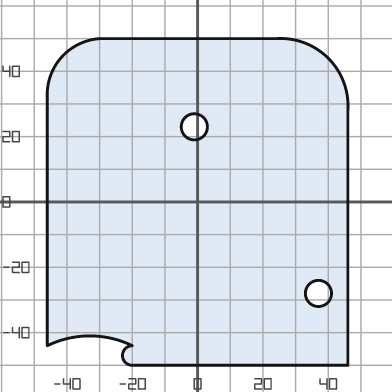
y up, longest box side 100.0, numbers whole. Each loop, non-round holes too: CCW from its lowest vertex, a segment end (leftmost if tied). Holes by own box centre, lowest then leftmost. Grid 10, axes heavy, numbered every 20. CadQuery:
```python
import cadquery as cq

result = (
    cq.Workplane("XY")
    .moveTo(-20.0, -50.0)
    .lineTo(46.0, -50.0)
    .lineTo(46.0, 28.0)
    .threePointArc((40.0, 44.0), (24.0, 50.0))
    .lineTo(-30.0, 50.0)
    .threePointArc((-41.0, 45.0), (-46.0, 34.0))
    .lineTo(-46.0, -44.0)
    .threePointArc((-33.0, -41.0), (-20.0, -44.0))
    .threePointArc((-23.0, -47.0), (-20.0, -50.0))
    .close()
    .moveTo(37.0, -28.0)
    .circle(4.0)
    .moveTo(-1.0, 23.0)
    .circle(4.0)
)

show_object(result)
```